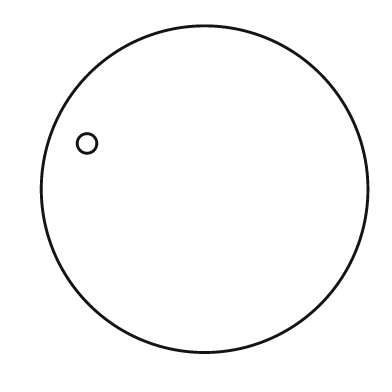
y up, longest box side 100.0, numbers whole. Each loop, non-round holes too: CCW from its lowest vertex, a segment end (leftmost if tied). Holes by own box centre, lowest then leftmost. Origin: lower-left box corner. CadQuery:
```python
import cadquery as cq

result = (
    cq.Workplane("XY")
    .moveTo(50.0, 50.0)
    .circle(50.0)
    .moveTo(14.0, 64.0)
    .circle(3.0)
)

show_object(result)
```